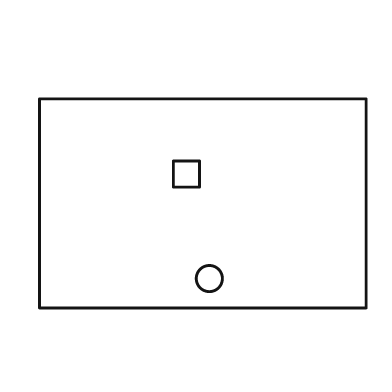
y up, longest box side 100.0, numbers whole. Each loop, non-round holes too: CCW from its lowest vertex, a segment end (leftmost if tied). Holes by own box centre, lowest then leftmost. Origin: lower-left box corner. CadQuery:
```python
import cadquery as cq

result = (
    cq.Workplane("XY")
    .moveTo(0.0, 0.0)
    .lineTo(100.0, 0.0)
    .lineTo(100.0, 64.0)
    .lineTo(0.0, 64.0)
    .close()
    .moveTo(52.0, 9.0)
    .circle(4.0)
    .moveTo(41.0, 37.0)
    .lineTo(49.0, 37.0)
    .lineTo(49.0, 45.0)
    .lineTo(41.0, 45.0)
    .close()
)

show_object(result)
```